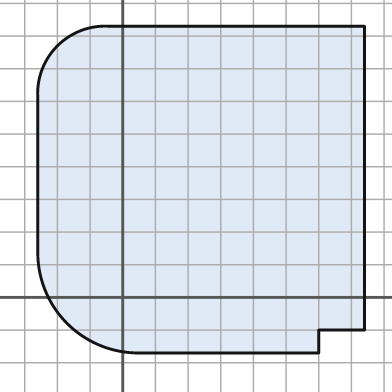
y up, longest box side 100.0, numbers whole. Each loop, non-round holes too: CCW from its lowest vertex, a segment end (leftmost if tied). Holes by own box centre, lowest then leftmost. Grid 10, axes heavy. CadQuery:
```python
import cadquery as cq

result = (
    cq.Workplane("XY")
    .moveTo(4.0, -17.0)
    .lineTo(60.0, -17.0)
    .lineTo(60.0, -10.0)
    .lineTo(74.0, -10.0)
    .lineTo(74.0, 83.0)
    .lineTo(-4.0, 83.0)
    .threePointArc((-20.0, 77.0), (-26.0, 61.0))
    .lineTo(-26.0, 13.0)
    .threePointArc((-17.0, -8.0), (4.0, -17.0))
    .close()
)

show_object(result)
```